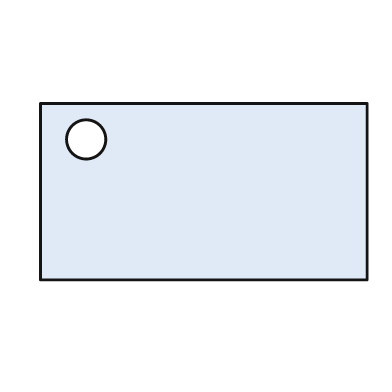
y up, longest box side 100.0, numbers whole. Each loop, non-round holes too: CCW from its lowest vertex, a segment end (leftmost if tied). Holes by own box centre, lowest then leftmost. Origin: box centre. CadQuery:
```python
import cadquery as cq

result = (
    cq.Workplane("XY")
    .moveTo(-50.0, -27.0)
    .lineTo(50.0, -27.0)
    .lineTo(50.0, 27.0)
    .lineTo(-50.0, 27.0)
    .close()
    .moveTo(-36.0, 16.0)
    .circle(6.0)
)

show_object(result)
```